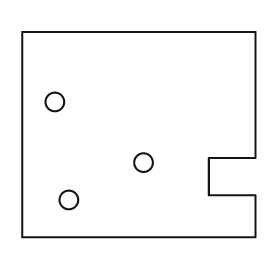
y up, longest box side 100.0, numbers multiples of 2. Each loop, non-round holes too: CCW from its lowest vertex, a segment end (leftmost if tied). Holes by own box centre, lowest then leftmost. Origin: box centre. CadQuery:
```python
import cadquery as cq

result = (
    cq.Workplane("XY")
    .moveTo(-50.0, -44.0)
    .lineTo(50.0, -44.0)
    .lineTo(50.0, -26.0)
    .lineTo(30.0, -26.0)
    .lineTo(30.0, -10.0)
    .lineTo(50.0, -10.0)
    .lineTo(50.0, 44.0)
    .lineTo(-50.0, 44.0)
    .close()
    .moveTo(-30.0, -28.0)
    .circle(4.0)
    .moveTo(2.0, -12.0)
    .circle(4.0)
    .moveTo(-36.0, 14.0)
    .circle(4.0)
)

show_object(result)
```